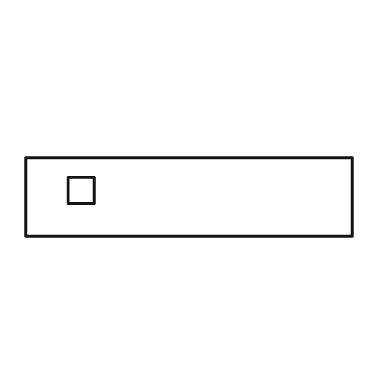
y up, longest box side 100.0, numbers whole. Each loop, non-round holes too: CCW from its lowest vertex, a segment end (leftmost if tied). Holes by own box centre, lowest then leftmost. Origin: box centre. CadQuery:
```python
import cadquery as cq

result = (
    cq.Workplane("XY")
    .moveTo(-50.0, -12.0)
    .lineTo(50.0, -12.0)
    .lineTo(50.0, 12.0)
    .lineTo(-50.0, 12.0)
    .close()
    .moveTo(-37.0, -2.0)
    .lineTo(-29.0, -2.0)
    .lineTo(-29.0, 6.0)
    .lineTo(-37.0, 6.0)
    .close()
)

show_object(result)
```